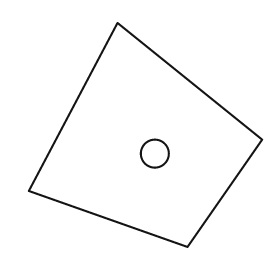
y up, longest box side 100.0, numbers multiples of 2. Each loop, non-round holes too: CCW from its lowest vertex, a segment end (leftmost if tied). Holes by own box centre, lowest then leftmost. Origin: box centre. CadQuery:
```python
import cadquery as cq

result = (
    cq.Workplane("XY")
    .moveTo(18.0, -48.0)
    .lineTo(50.0, -2.0)
    .lineTo(-12.0, 48.0)
    .lineTo(-50.0, -24.0)
    .close()
    .moveTo(4.0, -8.0)
    .circle(6.0)
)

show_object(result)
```